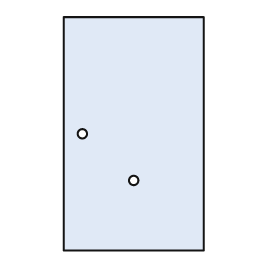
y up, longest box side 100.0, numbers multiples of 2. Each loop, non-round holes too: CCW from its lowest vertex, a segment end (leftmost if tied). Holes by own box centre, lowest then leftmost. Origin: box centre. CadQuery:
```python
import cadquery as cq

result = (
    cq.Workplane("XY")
    .moveTo(-30.0, -50.0)
    .lineTo(30.0, -50.0)
    .lineTo(30.0, 50.0)
    .lineTo(-30.0, 50.0)
    .close()
    .moveTo(0.0, -20.0)
    .circle(2.0)
    .moveTo(-22.0, 0.0)
    .circle(2.0)
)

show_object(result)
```